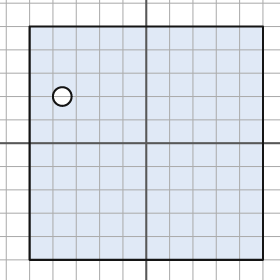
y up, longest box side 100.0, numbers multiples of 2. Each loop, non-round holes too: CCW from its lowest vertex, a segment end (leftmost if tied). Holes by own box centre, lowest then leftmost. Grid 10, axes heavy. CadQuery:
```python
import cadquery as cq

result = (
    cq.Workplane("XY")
    .moveTo(-50.0, -50.0)
    .lineTo(50.0, -50.0)
    .lineTo(50.0, 50.0)
    .lineTo(-50.0, 50.0)
    .close()
    .moveTo(-36.0, 20.0)
    .circle(4.0)
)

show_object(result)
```